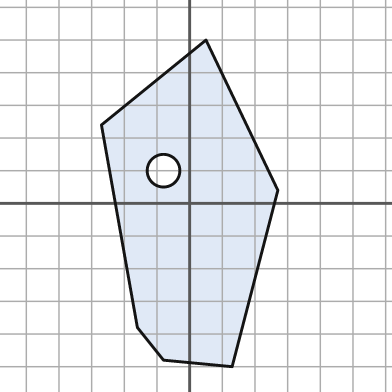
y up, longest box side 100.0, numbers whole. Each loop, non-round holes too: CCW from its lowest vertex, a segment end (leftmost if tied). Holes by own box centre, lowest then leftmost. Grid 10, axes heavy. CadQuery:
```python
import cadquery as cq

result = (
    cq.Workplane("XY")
    .moveTo(13.0, -50.0)
    .lineTo(27.0, 4.0)
    .lineTo(5.0, 50.0)
    .lineTo(-27.0, 24.0)
    .lineTo(-16.0, -38.0)
    .lineTo(-8.0, -48.0)
    .close()
    .moveTo(-8.0, 10.0)
    .circle(5.0)
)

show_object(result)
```